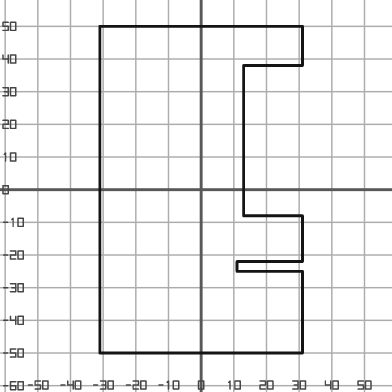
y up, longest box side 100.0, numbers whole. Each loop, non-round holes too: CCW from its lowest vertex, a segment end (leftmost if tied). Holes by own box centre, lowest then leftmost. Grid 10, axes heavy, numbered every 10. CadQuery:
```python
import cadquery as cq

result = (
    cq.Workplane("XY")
    .moveTo(-31.0, -50.0)
    .lineTo(31.0, -50.0)
    .lineTo(31.0, -25.0)
    .lineTo(11.0, -25.0)
    .lineTo(11.0, -22.0)
    .lineTo(31.0, -22.0)
    .lineTo(31.0, -8.0)
    .lineTo(13.0, -8.0)
    .lineTo(13.0, 38.0)
    .lineTo(31.0, 38.0)
    .lineTo(31.0, 50.0)
    .lineTo(-31.0, 50.0)
    .close()
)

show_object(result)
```